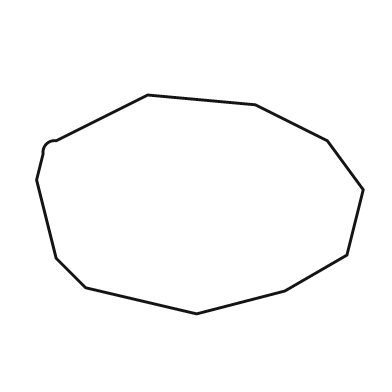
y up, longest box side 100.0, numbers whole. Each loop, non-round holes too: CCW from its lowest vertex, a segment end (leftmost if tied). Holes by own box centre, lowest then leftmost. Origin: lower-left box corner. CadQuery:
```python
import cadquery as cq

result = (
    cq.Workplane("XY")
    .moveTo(49.0, 0.0)
    .lineTo(76.0, 7.0)
    .lineTo(95.0, 18.0)
    .lineTo(100.0, 38.0)
    .lineTo(89.0, 53.0)
    .lineTo(67.0, 64.0)
    .lineTo(34.0, 67.0)
    .lineTo(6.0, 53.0)
    .threePointArc((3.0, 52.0), (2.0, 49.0))
    .lineTo(0.0, 41.0)
    .lineTo(6.0, 17.0)
    .lineTo(15.0, 8.0)
    .close()
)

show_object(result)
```